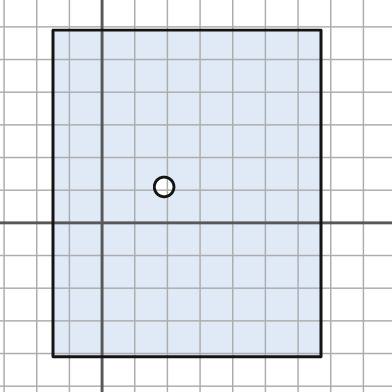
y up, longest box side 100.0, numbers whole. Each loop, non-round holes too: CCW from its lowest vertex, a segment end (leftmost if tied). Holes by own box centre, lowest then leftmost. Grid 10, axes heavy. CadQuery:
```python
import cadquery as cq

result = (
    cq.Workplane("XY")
    .moveTo(-15.0, -41.0)
    .lineTo(67.0, -41.0)
    .lineTo(67.0, 59.0)
    .lineTo(-15.0, 59.0)
    .close()
    .moveTo(19.0, 11.0)
    .circle(3.0)
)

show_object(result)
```